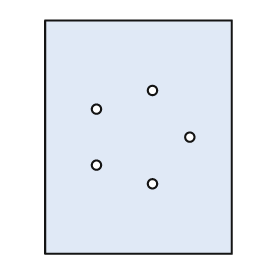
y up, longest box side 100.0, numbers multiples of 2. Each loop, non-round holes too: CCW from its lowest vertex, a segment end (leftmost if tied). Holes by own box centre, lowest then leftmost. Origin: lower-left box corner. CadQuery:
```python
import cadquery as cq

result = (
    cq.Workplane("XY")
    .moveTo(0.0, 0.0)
    .lineTo(80.0, 0.0)
    .lineTo(80.0, 100.0)
    .lineTo(0.0, 100.0)
    .close()
    .moveTo(46.0, 30.0)
    .circle(2.0)
    .moveTo(22.0, 38.0)
    .circle(2.0)
    .moveTo(62.0, 50.0)
    .circle(2.0)
    .moveTo(22.0, 62.0)
    .circle(2.0)
    .moveTo(46.0, 70.0)
    .circle(2.0)
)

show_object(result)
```